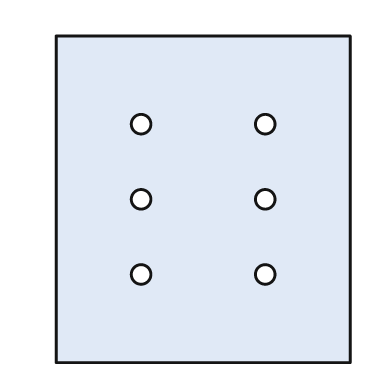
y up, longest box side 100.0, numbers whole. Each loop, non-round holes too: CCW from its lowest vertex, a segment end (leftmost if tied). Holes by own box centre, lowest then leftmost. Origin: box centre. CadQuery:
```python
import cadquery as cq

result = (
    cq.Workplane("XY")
    .moveTo(-45.0, -50.0)
    .lineTo(45.0, -50.0)
    .lineTo(45.0, 50.0)
    .lineTo(-45.0, 50.0)
    .close()
    .moveTo(-19.0, -23.0)
    .circle(3.0)
    .moveTo(19.0, -23.0)
    .circle(3.0)
    .moveTo(-19.0, 0.0)
    .circle(3.0)
    .moveTo(19.0, 0.0)
    .circle(3.0)
    .moveTo(-19.0, 23.0)
    .circle(3.0)
    .moveTo(19.0, 23.0)
    .circle(3.0)
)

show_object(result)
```